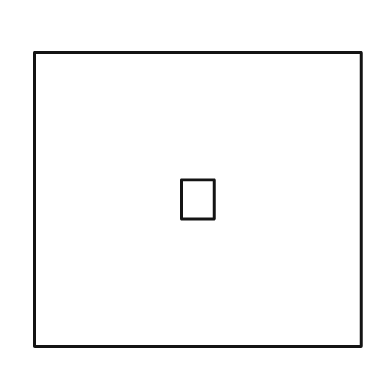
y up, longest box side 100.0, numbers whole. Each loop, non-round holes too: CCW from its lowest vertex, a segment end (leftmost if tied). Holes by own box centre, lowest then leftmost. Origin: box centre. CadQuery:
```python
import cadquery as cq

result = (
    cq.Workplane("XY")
    .moveTo(-50.0, -45.0)
    .lineTo(50.0, -45.0)
    .lineTo(50.0, 45.0)
    .lineTo(-50.0, 45.0)
    .close()
    .moveTo(-5.0, -6.0)
    .lineTo(5.0, -6.0)
    .lineTo(5.0, 6.0)
    .lineTo(-5.0, 6.0)
    .close()
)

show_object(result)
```